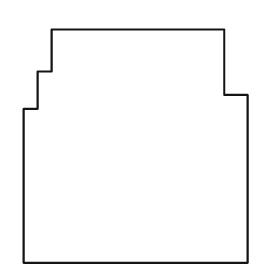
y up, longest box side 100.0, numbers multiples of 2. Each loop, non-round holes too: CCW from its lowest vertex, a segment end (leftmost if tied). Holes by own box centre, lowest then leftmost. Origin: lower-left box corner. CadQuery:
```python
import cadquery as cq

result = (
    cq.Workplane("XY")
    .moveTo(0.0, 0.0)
    .lineTo(96.0, 0.0)
    .lineTo(96.0, 72.0)
    .lineTo(86.0, 72.0)
    .lineTo(86.0, 100.0)
    .lineTo(12.0, 100.0)
    .lineTo(12.0, 82.0)
    .lineTo(6.0, 82.0)
    .lineTo(6.0, 66.0)
    .lineTo(0.0, 66.0)
    .close()
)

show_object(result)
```